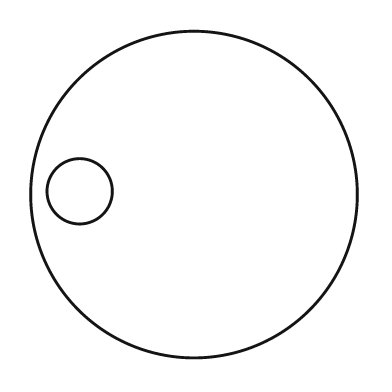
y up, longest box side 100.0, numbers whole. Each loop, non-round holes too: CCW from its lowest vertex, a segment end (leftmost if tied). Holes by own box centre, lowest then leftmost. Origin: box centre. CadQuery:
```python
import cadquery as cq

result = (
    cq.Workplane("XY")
    .moveTo(0.0, 0.0)
    .circle(50.0)
    .moveTo(-35.0, 1.0)
    .circle(10.0)
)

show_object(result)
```